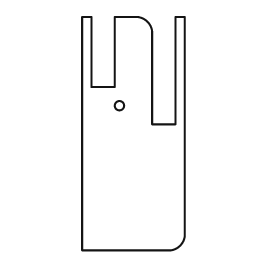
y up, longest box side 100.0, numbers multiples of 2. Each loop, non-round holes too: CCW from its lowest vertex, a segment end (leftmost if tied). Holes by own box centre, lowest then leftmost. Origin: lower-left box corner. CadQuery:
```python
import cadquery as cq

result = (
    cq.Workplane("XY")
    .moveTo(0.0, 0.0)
    .lineTo(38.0, 0.0)
    .threePointArc((42.0, 2.0), (44.0, 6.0))
    .lineTo(44.0, 100.0)
    .lineTo(40.0, 100.0)
    .lineTo(40.0, 54.0)
    .lineTo(30.0, 54.0)
    .lineTo(30.0, 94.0)
    .threePointArc((28.0, 98.0), (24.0, 100.0))
    .lineTo(14.0, 100.0)
    .lineTo(14.0, 70.0)
    .lineTo(4.0, 70.0)
    .lineTo(4.0, 100.0)
    .lineTo(0.0, 100.0)
    .close()
    .moveTo(16.0, 62.0)
    .circle(2.0)
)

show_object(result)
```